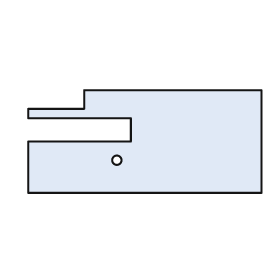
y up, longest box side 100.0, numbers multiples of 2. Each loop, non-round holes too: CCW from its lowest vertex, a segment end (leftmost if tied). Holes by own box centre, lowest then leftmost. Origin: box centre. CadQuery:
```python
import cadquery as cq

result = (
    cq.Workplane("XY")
    .moveTo(-50.0, -22.0)
    .lineTo(50.0, -22.0)
    .lineTo(50.0, 22.0)
    .lineTo(-26.0, 22.0)
    .lineTo(-26.0, 14.0)
    .lineTo(-50.0, 14.0)
    .lineTo(-50.0, 10.0)
    .lineTo(-6.0, 10.0)
    .lineTo(-6.0, 0.0)
    .lineTo(-50.0, 0.0)
    .close()
    .moveTo(-12.0, -8.0)
    .circle(2.0)
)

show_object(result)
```